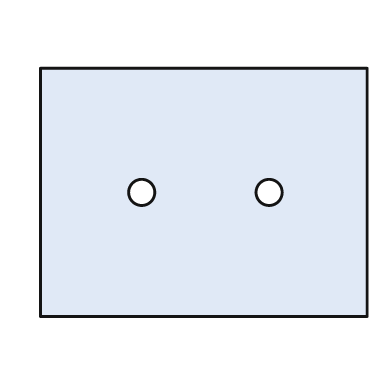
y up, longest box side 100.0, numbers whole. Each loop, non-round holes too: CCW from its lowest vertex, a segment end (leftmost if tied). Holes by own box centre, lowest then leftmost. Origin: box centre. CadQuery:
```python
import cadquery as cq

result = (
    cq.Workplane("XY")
    .moveTo(-50.0, -38.0)
    .lineTo(50.0, -38.0)
    .lineTo(50.0, 38.0)
    .lineTo(-50.0, 38.0)
    .close()
    .moveTo(-19.0, 0.0)
    .circle(4.0)
    .moveTo(20.0, 0.0)
    .circle(4.0)
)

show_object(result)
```